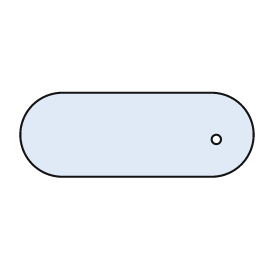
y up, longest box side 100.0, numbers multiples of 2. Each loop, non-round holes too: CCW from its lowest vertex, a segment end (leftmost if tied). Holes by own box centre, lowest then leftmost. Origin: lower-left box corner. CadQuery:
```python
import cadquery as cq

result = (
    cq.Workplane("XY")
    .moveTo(18.0, 0.0)
    .lineTo(82.0, 0.0)
    .threePointArc((100.0, 18.0), (82.0, 36.0))
    .lineTo(18.0, 36.0)
    .threePointArc((0.0, 18.0), (18.0, 0.0))
    .close()
    .moveTo(84.0, 16.0)
    .circle(2.0)
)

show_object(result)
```